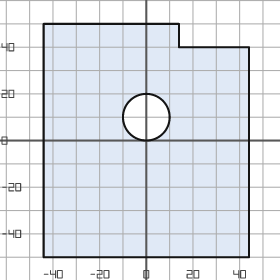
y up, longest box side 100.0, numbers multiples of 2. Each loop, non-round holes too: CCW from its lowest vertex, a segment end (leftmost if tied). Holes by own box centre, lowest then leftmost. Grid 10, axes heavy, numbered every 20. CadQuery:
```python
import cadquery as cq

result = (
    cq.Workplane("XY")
    .moveTo(-44.0, -50.0)
    .lineTo(44.0, -50.0)
    .lineTo(44.0, 40.0)
    .lineTo(14.0, 40.0)
    .lineTo(14.0, 50.0)
    .lineTo(-44.0, 50.0)
    .close()
    .moveTo(0.0, 10.0)
    .circle(10.0)
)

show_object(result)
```